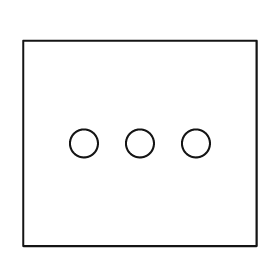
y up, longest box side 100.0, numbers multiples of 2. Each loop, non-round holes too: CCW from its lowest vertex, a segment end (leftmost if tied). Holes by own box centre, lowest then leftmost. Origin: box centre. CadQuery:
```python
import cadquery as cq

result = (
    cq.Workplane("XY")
    .moveTo(-50.0, -44.0)
    .lineTo(50.0, -44.0)
    .lineTo(50.0, 44.0)
    .lineTo(-50.0, 44.0)
    .close()
    .moveTo(-24.0, 0.0)
    .circle(6.0)
    .moveTo(0.0, 0.0)
    .circle(6.0)
    .moveTo(24.0, 0.0)
    .circle(6.0)
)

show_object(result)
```